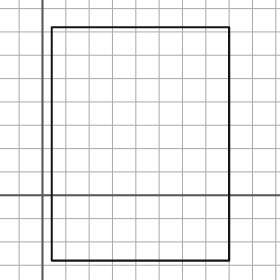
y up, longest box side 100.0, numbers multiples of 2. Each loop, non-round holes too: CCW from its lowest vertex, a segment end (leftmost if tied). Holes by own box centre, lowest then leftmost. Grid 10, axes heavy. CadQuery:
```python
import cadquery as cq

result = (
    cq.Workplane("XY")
    .moveTo(4.0, -28.0)
    .lineTo(80.0, -28.0)
    .lineTo(80.0, 72.0)
    .lineTo(4.0, 72.0)
    .close()
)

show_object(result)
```